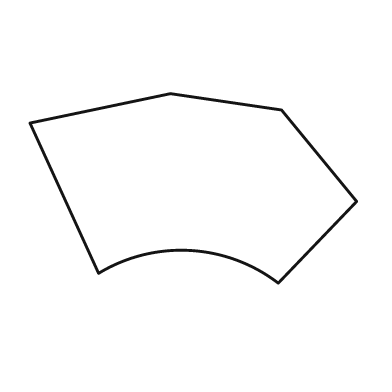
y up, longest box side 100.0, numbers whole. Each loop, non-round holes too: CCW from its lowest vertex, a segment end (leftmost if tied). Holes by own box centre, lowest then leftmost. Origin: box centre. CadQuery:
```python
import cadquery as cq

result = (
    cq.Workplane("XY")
    .moveTo(26.0, -29.0)
    .lineTo(50.0, -4.0)
    .lineTo(27.0, 24.0)
    .lineTo(-7.0, 29.0)
    .lineTo(-50.0, 20.0)
    .lineTo(-29.0, -26.0)
    .threePointArc((-1.0, -19.0), (26.0, -29.0))
    .close()
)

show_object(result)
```